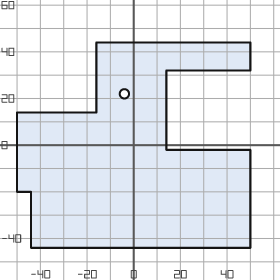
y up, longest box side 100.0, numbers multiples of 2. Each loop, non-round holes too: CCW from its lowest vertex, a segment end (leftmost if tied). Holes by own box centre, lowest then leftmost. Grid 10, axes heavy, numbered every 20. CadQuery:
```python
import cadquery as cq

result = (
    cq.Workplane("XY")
    .moveTo(-44.0, -44.0)
    .lineTo(50.0, -44.0)
    .lineTo(50.0, -2.0)
    .lineTo(14.0, -2.0)
    .lineTo(14.0, 32.0)
    .lineTo(50.0, 32.0)
    .lineTo(50.0, 44.0)
    .lineTo(-16.0, 44.0)
    .lineTo(-16.0, 14.0)
    .lineTo(-50.0, 14.0)
    .lineTo(-50.0, -20.0)
    .lineTo(-44.0, -20.0)
    .close()
    .moveTo(-4.0, 22.0)
    .circle(2.0)
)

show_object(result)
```